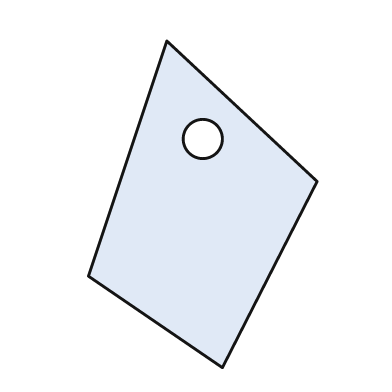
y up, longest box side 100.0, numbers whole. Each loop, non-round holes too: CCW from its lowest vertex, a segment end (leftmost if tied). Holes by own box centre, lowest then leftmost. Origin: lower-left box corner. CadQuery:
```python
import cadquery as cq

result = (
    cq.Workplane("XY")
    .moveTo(41.0, 0.0)
    .lineTo(70.0, 57.0)
    .lineTo(24.0, 100.0)
    .lineTo(0.0, 28.0)
    .close()
    .moveTo(35.0, 70.0)
    .circle(6.0)
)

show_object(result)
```